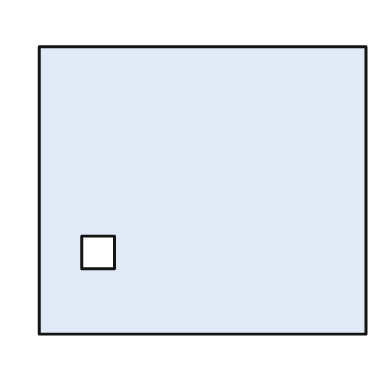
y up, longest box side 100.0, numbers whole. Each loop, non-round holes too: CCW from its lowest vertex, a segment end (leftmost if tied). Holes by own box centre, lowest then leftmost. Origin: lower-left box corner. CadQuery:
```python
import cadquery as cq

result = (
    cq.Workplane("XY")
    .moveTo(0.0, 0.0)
    .lineTo(100.0, 0.0)
    .lineTo(100.0, 88.0)
    .lineTo(0.0, 88.0)
    .close()
    .moveTo(13.0, 20.0)
    .lineTo(23.0, 20.0)
    .lineTo(23.0, 30.0)
    .lineTo(13.0, 30.0)
    .close()
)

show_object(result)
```